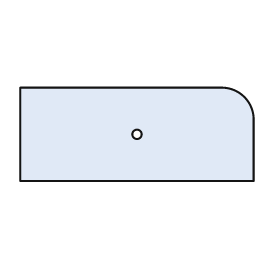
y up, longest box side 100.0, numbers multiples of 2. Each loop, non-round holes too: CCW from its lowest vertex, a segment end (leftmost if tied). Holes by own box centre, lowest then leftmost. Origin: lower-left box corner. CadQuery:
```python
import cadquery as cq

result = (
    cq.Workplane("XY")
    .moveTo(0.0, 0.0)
    .lineTo(100.0, 0.0)
    .lineTo(100.0, 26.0)
    .threePointArc((96.0, 36.0), (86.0, 40.0))
    .lineTo(0.0, 40.0)
    .close()
    .moveTo(50.0, 20.0)
    .circle(2.0)
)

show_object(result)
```